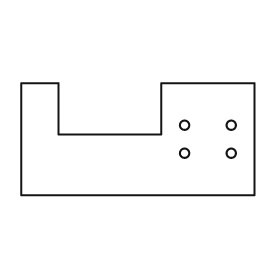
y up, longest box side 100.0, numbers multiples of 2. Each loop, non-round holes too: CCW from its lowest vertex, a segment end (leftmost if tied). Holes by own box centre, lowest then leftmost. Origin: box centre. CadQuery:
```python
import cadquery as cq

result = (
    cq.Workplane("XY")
    .moveTo(-50.0, -24.0)
    .lineTo(50.0, -24.0)
    .lineTo(50.0, 24.0)
    .lineTo(10.0, 24.0)
    .lineTo(10.0, 2.0)
    .lineTo(-34.0, 2.0)
    .lineTo(-34.0, 24.0)
    .lineTo(-50.0, 24.0)
    .close()
    .moveTo(20.0, -6.0)
    .circle(2.0)
    .moveTo(40.0, -6.0)
    .circle(2.0)
    .moveTo(20.0, 6.0)
    .circle(2.0)
    .moveTo(40.0, 6.0)
    .circle(2.0)
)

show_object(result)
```